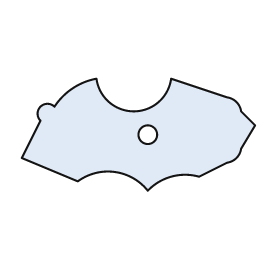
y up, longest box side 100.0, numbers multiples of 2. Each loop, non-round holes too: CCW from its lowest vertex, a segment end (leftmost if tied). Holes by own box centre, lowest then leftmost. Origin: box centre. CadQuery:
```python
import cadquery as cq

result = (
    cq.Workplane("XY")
    .moveTo(4.0, -24.0)
    .threePointArc((14.0, -18.0), (26.0, -18.0))
    .lineTo(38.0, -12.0)
    .threePointArc((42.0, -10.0), (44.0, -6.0))
    .lineTo(50.0, 4.0)
    .lineTo(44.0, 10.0)
    .threePointArc((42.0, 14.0), (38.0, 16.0))
    .lineTo(14.0, 24.0)
    .threePointArc((-2.0, 10.0), (-18.0, 24.0))
    .threePointArc((-28.0, 20.0), (-36.0, 12.0))
    .threePointArc((-42.0, 12.0), (-42.0, 6.0))
    .lineTo(-50.0, -10.0)
    .lineTo(-26.0, -20.0)
    .threePointArc((-10.0, -16.0), (4.0, -24.0))
    .close()
    .moveTo(4.0, 0.0)
    .circle(4.0)
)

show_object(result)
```